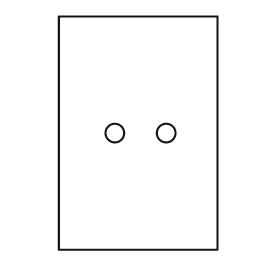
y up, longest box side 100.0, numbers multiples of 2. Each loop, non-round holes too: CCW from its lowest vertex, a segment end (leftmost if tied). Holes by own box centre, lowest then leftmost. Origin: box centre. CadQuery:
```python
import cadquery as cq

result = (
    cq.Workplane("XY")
    .moveTo(-34.0, -50.0)
    .lineTo(34.0, -50.0)
    .lineTo(34.0, 50.0)
    .lineTo(-34.0, 50.0)
    .close()
    .moveTo(-10.0, 0.0)
    .circle(4.0)
    .moveTo(12.0, 0.0)
    .circle(4.0)
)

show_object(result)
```